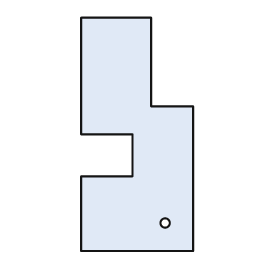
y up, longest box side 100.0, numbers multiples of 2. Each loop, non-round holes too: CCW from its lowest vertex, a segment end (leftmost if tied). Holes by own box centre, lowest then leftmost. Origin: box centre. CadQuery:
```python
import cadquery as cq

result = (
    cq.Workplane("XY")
    .moveTo(-24.0, -50.0)
    .lineTo(24.0, -50.0)
    .lineTo(24.0, 12.0)
    .lineTo(6.0, 12.0)
    .lineTo(6.0, 50.0)
    .lineTo(-24.0, 50.0)
    .lineTo(-24.0, 0.0)
    .lineTo(-2.0, 0.0)
    .lineTo(-2.0, -18.0)
    .lineTo(-24.0, -18.0)
    .close()
    .moveTo(12.0, -38.0)
    .circle(2.0)
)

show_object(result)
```